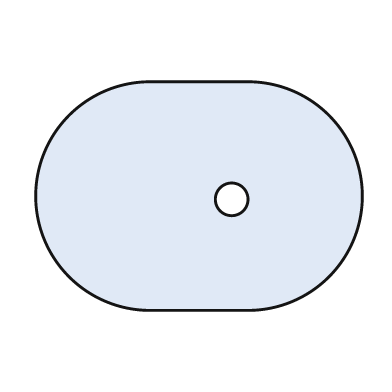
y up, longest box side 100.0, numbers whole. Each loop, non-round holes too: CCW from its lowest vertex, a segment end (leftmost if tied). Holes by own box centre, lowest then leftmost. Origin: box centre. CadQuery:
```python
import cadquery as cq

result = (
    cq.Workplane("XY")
    .moveTo(-15.0, -35.0)
    .lineTo(15.0, -35.0)
    .threePointArc((50.0, 0.0), (15.0, 35.0))
    .lineTo(-15.0, 35.0)
    .threePointArc((-50.0, 0.0), (-15.0, -35.0))
    .close()
    .moveTo(10.0, -1.0)
    .circle(5.0)
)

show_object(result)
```